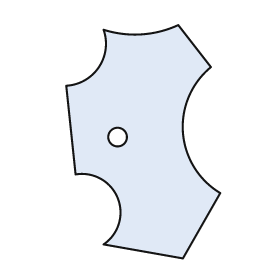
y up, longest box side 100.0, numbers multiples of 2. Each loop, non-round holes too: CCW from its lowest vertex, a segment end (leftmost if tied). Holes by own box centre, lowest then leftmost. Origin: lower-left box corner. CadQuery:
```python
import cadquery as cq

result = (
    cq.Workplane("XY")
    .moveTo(50.0, 0.0)
    .lineTo(66.0, 28.0)
    .threePointArc((50.0, 54.0), (62.0, 82.0))
    .lineTo(48.0, 100.0)
    .threePointArc((32.0, 96.0), (16.0, 98.0))
    .threePointArc((14.0, 82.0), (0.0, 74.0))
    .lineTo(4.0, 36.0)
    .threePointArc((22.0, 26.0), (16.0, 6.0))
    .close()
    .moveTo(22.0, 52.0)
    .circle(4.0)
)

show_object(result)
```